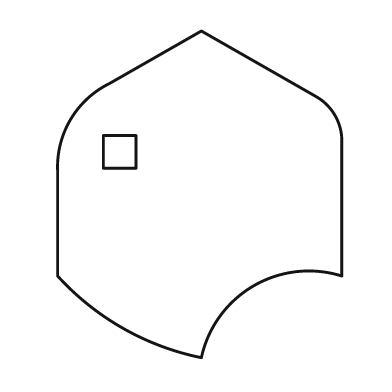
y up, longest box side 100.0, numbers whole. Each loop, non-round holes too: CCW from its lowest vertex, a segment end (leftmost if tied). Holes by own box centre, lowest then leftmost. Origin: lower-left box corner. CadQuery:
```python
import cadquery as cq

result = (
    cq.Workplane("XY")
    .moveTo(44.0, 0.0)
    .threePointArc((60.0, 22.0), (87.0, 25.0))
    .lineTo(87.0, 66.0)
    .threePointArc((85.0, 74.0), (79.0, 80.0))
    .lineTo(44.0, 100.0)
    .lineTo(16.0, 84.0)
    .threePointArc((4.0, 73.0), (0.0, 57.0))
    .lineTo(0.0, 25.0)
    .threePointArc((20.0, 9.0), (44.0, 0.0))
    .close()
    .moveTo(14.0, 58.0)
    .lineTo(24.0, 58.0)
    .lineTo(24.0, 68.0)
    .lineTo(14.0, 68.0)
    .close()
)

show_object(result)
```